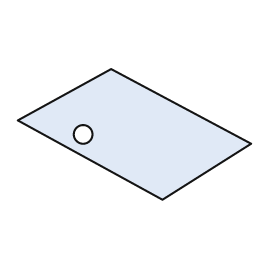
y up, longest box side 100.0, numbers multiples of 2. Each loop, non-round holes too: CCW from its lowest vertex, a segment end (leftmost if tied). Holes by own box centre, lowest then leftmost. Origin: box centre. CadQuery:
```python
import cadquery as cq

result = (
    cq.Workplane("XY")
    .moveTo(12.0, -28.0)
    .lineTo(50.0, -4.0)
    .lineTo(-10.0, 28.0)
    .lineTo(-50.0, 6.0)
    .close()
    .moveTo(-22.0, 0.0)
    .circle(4.0)
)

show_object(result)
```